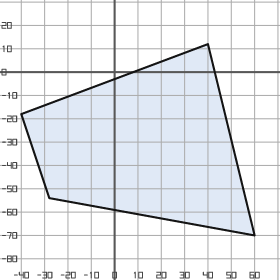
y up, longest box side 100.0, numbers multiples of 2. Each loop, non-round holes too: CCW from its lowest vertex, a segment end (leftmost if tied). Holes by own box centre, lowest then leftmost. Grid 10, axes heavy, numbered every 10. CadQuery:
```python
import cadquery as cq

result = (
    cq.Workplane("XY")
    .moveTo(60.0, -70.0)
    .lineTo(40.0, 12.0)
    .lineTo(-40.0, -18.0)
    .lineTo(-28.0, -54.0)
    .close()
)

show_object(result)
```